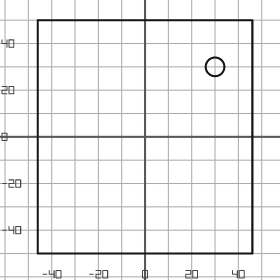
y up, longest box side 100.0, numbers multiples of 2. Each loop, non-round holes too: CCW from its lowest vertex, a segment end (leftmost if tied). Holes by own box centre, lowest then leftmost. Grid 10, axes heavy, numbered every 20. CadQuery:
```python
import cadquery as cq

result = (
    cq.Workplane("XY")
    .moveTo(-46.0, -50.0)
    .lineTo(46.0, -50.0)
    .lineTo(46.0, 50.0)
    .lineTo(-46.0, 50.0)
    .close()
    .moveTo(30.0, 30.0)
    .circle(4.0)
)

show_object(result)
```